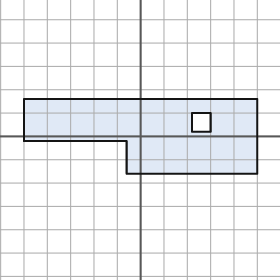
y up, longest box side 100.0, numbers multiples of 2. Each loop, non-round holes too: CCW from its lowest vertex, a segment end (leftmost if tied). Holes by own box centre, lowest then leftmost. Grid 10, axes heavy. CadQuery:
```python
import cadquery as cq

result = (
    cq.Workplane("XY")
    .moveTo(-6.0, -16.0)
    .lineTo(50.0, -16.0)
    .lineTo(50.0, 16.0)
    .lineTo(-50.0, 16.0)
    .lineTo(-50.0, -2.0)
    .lineTo(-6.0, -2.0)
    .close()
    .moveTo(22.0, 2.0)
    .lineTo(30.0, 2.0)
    .lineTo(30.0, 10.0)
    .lineTo(22.0, 10.0)
    .close()
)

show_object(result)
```